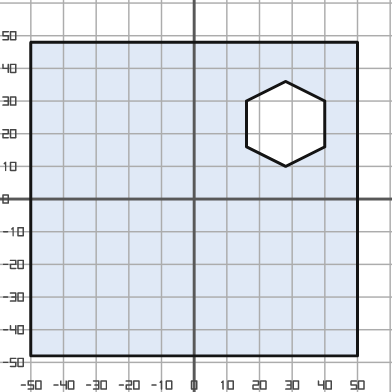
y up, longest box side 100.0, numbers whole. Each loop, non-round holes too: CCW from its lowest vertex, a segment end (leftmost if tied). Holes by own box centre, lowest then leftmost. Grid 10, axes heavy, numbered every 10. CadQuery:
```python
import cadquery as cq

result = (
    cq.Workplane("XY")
    .moveTo(-50.0, -48.0)
    .lineTo(50.0, -48.0)
    .lineTo(50.0, 48.0)
    .lineTo(-50.0, 48.0)
    .close()
    .moveTo(28.0, 10.0)
    .lineTo(40.0, 16.0)
    .lineTo(40.0, 30.0)
    .lineTo(28.0, 36.0)
    .lineTo(16.0, 30.0)
    .lineTo(16.0, 16.0)
    .close()
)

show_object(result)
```